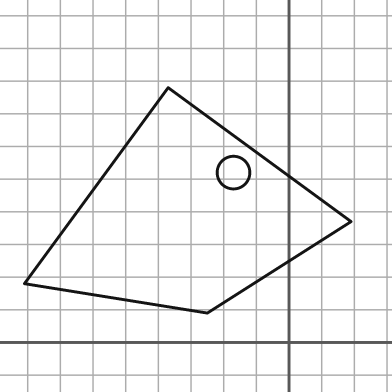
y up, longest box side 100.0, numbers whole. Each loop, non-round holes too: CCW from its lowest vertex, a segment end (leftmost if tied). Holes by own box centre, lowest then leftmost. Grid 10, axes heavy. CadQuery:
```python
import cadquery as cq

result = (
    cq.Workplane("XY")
    .moveTo(-25.0, 9.0)
    .lineTo(19.0, 37.0)
    .lineTo(-37.0, 78.0)
    .lineTo(-81.0, 18.0)
    .close()
    .moveTo(-17.0, 52.0)
    .circle(5.0)
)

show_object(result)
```